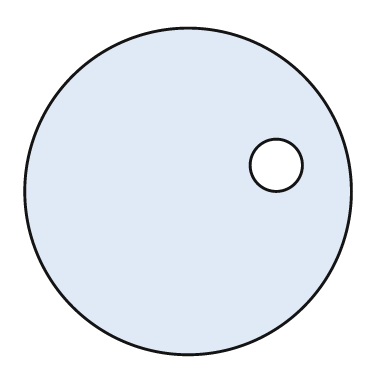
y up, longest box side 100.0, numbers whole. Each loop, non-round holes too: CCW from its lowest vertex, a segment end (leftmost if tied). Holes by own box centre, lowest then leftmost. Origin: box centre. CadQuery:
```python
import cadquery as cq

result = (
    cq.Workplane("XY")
    .moveTo(0.0, 0.0)
    .circle(50.0)
    .moveTo(27.0, 8.0)
    .circle(8.0)
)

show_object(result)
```